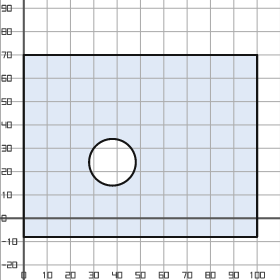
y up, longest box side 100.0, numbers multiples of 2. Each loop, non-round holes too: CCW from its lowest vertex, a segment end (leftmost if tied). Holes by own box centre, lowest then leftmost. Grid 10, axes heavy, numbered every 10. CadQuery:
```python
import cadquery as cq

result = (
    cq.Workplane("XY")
    .moveTo(0.0, -8.0)
    .lineTo(100.0, -8.0)
    .lineTo(100.0, 70.0)
    .lineTo(0.0, 70.0)
    .close()
    .moveTo(38.0, 24.0)
    .circle(10.0)
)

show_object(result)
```